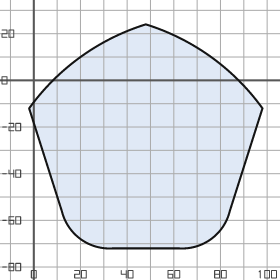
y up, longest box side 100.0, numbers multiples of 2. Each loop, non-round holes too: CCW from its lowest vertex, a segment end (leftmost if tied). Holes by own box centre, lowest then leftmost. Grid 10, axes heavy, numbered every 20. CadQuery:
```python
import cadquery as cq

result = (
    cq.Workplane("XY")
    .moveTo(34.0, -72.0)
    .lineTo(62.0, -72.0)
    .threePointArc((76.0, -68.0), (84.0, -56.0))
    .lineTo(98.0, -12.0)
    .threePointArc((76.0, 10.0), (48.0, 24.0))
    .threePointArc((20.0, 10.0), (-2.0, -12.0))
    .lineTo(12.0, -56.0)
    .threePointArc((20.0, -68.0), (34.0, -72.0))
    .close()
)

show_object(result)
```